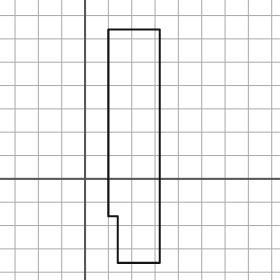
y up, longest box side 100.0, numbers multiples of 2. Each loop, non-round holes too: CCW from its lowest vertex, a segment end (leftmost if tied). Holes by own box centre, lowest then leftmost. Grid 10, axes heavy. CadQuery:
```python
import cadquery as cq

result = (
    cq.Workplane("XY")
    .moveTo(14.0, -36.0)
    .lineTo(32.0, -36.0)
    .lineTo(32.0, 64.0)
    .lineTo(10.0, 64.0)
    .lineTo(10.0, -16.0)
    .lineTo(14.0, -16.0)
    .close()
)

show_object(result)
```